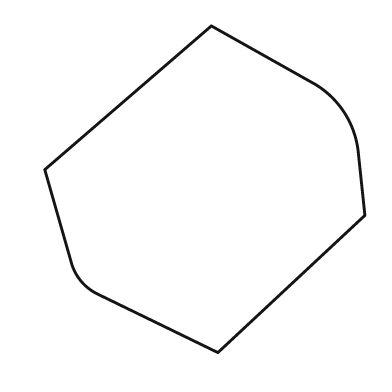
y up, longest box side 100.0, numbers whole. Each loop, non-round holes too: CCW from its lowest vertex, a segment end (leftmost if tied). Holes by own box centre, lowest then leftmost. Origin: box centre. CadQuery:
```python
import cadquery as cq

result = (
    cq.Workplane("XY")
    .moveTo(4.0, -50.0)
    .lineTo(49.0, -8.0)
    .lineTo(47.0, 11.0)
    .threePointArc((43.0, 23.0), (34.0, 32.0))
    .lineTo(2.0, 50.0)
    .lineTo(-49.0, 6.0)
    .lineTo(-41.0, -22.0)
    .threePointArc((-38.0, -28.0), (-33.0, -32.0))
    .close()
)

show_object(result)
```